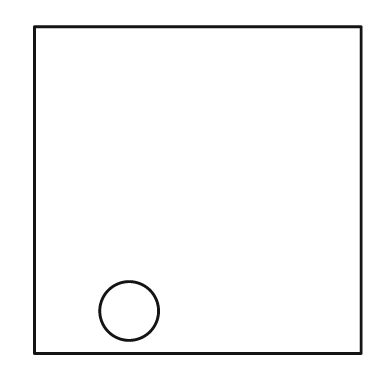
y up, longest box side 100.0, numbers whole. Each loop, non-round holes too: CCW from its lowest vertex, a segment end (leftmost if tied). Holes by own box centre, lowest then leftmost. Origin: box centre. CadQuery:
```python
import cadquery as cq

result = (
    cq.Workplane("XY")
    .moveTo(-50.0, -50.0)
    .lineTo(50.0, -50.0)
    .lineTo(50.0, 50.0)
    .lineTo(-50.0, 50.0)
    .close()
    .moveTo(-21.0, -37.0)
    .circle(9.0)
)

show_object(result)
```